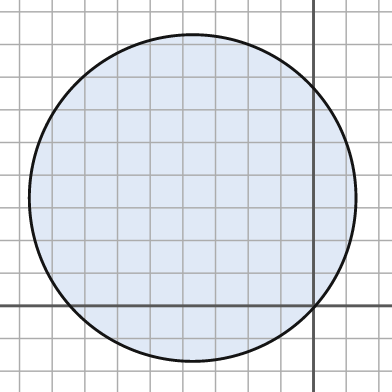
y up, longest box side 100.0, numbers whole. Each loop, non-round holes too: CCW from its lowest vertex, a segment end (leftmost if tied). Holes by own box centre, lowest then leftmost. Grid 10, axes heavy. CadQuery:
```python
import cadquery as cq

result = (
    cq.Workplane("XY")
    .moveTo(-37.0, 33.0)
    .circle(50.0)
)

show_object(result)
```